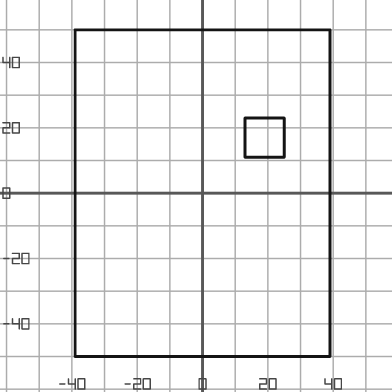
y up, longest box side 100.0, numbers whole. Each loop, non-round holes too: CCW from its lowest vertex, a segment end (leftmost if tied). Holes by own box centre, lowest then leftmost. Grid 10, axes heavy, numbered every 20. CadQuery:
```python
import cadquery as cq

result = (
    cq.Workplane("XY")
    .moveTo(-39.0, -50.0)
    .lineTo(39.0, -50.0)
    .lineTo(39.0, 50.0)
    .lineTo(-39.0, 50.0)
    .close()
    .moveTo(13.0, 11.0)
    .lineTo(25.0, 11.0)
    .lineTo(25.0, 23.0)
    .lineTo(13.0, 23.0)
    .close()
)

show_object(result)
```